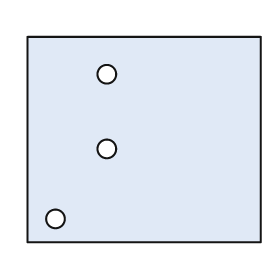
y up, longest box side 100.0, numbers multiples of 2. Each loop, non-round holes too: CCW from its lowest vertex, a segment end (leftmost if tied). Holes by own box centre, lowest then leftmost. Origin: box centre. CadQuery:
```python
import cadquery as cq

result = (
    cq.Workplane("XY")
    .moveTo(-50.0, -44.0)
    .lineTo(50.0, -44.0)
    .lineTo(50.0, 44.0)
    .lineTo(-50.0, 44.0)
    .close()
    .moveTo(-38.0, -34.0)
    .circle(4.0)
    .moveTo(-16.0, -4.0)
    .circle(4.0)
    .moveTo(-16.0, 28.0)
    .circle(4.0)
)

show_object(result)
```